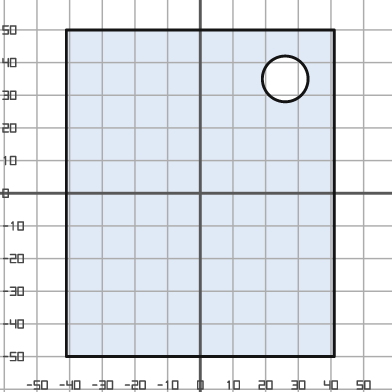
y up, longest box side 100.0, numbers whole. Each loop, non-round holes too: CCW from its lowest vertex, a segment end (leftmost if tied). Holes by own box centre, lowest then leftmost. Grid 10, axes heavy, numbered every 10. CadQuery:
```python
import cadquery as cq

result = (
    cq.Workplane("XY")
    .moveTo(-41.0, -50.0)
    .lineTo(41.0, -50.0)
    .lineTo(41.0, 50.0)
    .lineTo(-41.0, 50.0)
    .close()
    .moveTo(26.0, 35.0)
    .circle(7.0)
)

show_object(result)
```